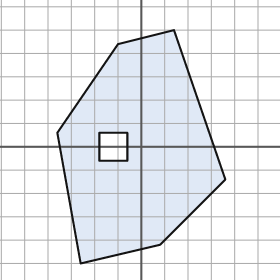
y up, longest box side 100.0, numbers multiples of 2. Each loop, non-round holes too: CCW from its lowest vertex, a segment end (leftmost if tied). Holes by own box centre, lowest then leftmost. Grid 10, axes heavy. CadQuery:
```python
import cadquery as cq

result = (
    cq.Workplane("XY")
    .moveTo(-26.0, -50.0)
    .lineTo(8.0, -42.0)
    .lineTo(36.0, -14.0)
    .lineTo(14.0, 50.0)
    .lineTo(-10.0, 44.0)
    .lineTo(-36.0, 6.0)
    .close()
    .moveTo(-18.0, -6.0)
    .lineTo(-6.0, -6.0)
    .lineTo(-6.0, 6.0)
    .lineTo(-18.0, 6.0)
    .close()
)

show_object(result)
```